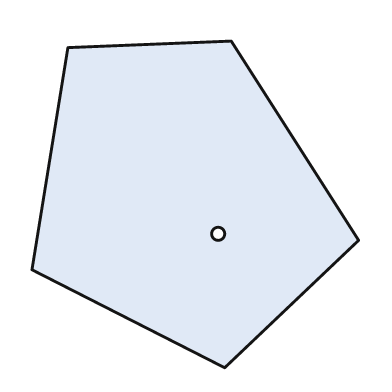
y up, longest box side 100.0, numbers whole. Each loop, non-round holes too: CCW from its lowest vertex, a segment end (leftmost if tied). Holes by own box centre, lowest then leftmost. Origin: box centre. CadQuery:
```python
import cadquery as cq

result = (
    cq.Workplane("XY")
    .moveTo(9.0, -50.0)
    .lineTo(50.0, -11.0)
    .lineTo(11.0, 50.0)
    .lineTo(-39.0, 48.0)
    .lineTo(-50.0, -20.0)
    .close()
    .moveTo(7.0, -9.0)
    .circle(2.0)
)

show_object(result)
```